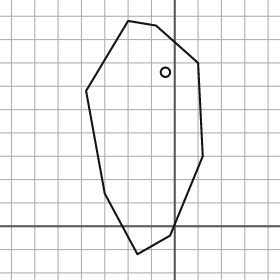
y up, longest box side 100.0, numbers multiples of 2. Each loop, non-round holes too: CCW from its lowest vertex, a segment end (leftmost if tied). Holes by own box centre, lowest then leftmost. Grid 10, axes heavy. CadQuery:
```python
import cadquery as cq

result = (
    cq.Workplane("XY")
    .moveTo(-16.0, -12.0)
    .lineTo(-2.0, -4.0)
    .lineTo(12.0, 30.0)
    .lineTo(10.0, 70.0)
    .lineTo(-8.0, 86.0)
    .lineTo(-20.0, 88.0)
    .lineTo(-38.0, 58.0)
    .lineTo(-30.0, 14.0)
    .close()
    .moveTo(-4.0, 66.0)
    .circle(2.0)
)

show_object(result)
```